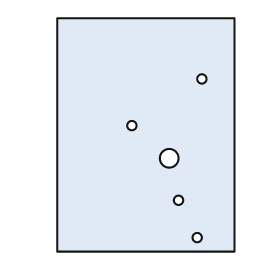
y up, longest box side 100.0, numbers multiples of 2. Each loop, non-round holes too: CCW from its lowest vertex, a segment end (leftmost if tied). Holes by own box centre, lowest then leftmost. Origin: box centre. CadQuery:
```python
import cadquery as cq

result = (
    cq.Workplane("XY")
    .moveTo(-38.0, -50.0)
    .lineTo(38.0, -50.0)
    .lineTo(38.0, 50.0)
    .lineTo(-38.0, 50.0)
    .close()
    .moveTo(22.0, -44.0)
    .circle(2.0)
    .moveTo(14.0, -28.0)
    .circle(2.0)
    .moveTo(10.0, -10.0)
    .circle(4.0)
    .moveTo(-6.0, 4.0)
    .circle(2.0)
    .moveTo(24.0, 24.0)
    .circle(2.0)
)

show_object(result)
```